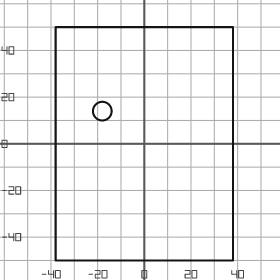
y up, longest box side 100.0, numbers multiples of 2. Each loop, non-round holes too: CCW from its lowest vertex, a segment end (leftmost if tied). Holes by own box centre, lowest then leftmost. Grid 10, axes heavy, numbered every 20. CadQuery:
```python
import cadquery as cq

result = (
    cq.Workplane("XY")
    .moveTo(-38.0, -50.0)
    .lineTo(38.0, -50.0)
    .lineTo(38.0, 50.0)
    .lineTo(-38.0, 50.0)
    .close()
    .moveTo(-18.0, 14.0)
    .circle(4.0)
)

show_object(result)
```